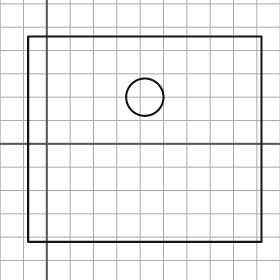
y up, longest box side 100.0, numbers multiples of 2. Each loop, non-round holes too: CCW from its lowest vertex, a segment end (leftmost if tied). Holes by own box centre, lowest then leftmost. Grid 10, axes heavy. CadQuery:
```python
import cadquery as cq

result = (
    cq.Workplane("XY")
    .moveTo(-8.0, -42.0)
    .lineTo(92.0, -42.0)
    .lineTo(92.0, 46.0)
    .lineTo(-8.0, 46.0)
    .close()
    .moveTo(42.0, 20.0)
    .circle(8.0)
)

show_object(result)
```